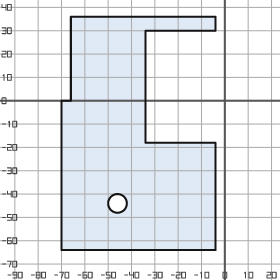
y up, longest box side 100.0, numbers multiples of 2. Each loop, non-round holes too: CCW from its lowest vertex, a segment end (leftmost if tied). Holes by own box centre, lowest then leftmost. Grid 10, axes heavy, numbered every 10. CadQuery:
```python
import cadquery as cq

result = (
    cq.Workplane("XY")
    .moveTo(-70.0, -64.0)
    .lineTo(-4.0, -64.0)
    .lineTo(-4.0, -18.0)
    .lineTo(-34.0, -18.0)
    .lineTo(-34.0, 30.0)
    .lineTo(-4.0, 30.0)
    .lineTo(-4.0, 36.0)
    .lineTo(-66.0, 36.0)
    .lineTo(-66.0, 0.0)
    .lineTo(-70.0, 0.0)
    .close()
    .moveTo(-46.0, -44.0)
    .circle(4.0)
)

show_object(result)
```